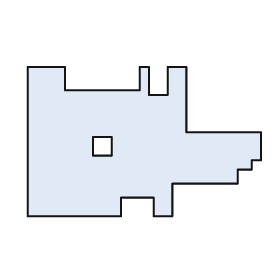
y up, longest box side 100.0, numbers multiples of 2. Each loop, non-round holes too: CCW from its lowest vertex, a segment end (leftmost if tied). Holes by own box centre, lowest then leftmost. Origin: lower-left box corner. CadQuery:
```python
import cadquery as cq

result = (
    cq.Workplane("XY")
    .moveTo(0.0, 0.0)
    .lineTo(40.0, 0.0)
    .lineTo(40.0, 8.0)
    .lineTo(54.0, 8.0)
    .lineTo(54.0, 0.0)
    .lineTo(62.0, 0.0)
    .lineTo(62.0, 14.0)
    .lineTo(90.0, 14.0)
    .lineTo(90.0, 20.0)
    .lineTo(96.0, 20.0)
    .lineTo(96.0, 24.0)
    .lineTo(100.0, 24.0)
    .lineTo(100.0, 36.0)
    .lineTo(68.0, 36.0)
    .lineTo(68.0, 64.0)
    .lineTo(60.0, 64.0)
    .lineTo(60.0, 52.0)
    .lineTo(52.0, 52.0)
    .lineTo(52.0, 64.0)
    .lineTo(48.0, 64.0)
    .lineTo(48.0, 54.0)
    .lineTo(16.0, 54.0)
    .lineTo(16.0, 64.0)
    .lineTo(0.0, 64.0)
    .close()
    .moveTo(28.0, 26.0)
    .lineTo(36.0, 26.0)
    .lineTo(36.0, 34.0)
    .lineTo(28.0, 34.0)
    .close()
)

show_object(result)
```